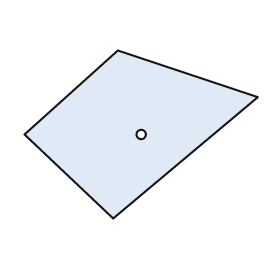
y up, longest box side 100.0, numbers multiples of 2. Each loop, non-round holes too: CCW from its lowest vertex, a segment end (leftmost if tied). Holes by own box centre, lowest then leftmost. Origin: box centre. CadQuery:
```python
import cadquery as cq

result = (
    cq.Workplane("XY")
    .moveTo(-12.0, -36.0)
    .lineTo(50.0, 16.0)
    .lineTo(-10.0, 36.0)
    .lineTo(-50.0, 0.0)
    .close()
    .moveTo(0.0, 0.0)
    .circle(2.0)
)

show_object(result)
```